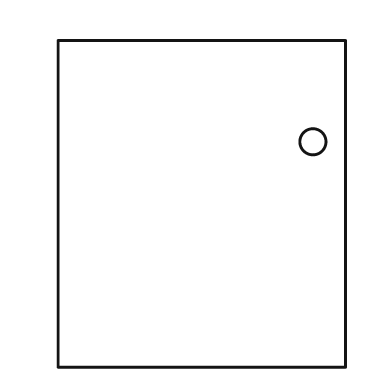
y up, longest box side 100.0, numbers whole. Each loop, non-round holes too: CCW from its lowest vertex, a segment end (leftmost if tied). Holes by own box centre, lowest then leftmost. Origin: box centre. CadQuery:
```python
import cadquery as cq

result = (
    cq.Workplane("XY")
    .moveTo(-44.0, -50.0)
    .lineTo(44.0, -50.0)
    .lineTo(44.0, 50.0)
    .lineTo(-44.0, 50.0)
    .close()
    .moveTo(34.0, 19.0)
    .circle(4.0)
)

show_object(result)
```